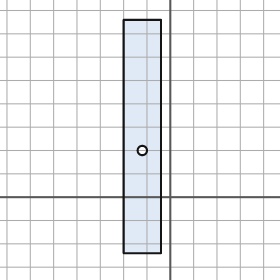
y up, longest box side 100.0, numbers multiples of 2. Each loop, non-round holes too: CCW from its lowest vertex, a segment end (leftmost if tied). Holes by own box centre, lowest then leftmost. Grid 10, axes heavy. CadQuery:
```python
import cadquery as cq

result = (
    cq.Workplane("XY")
    .moveTo(-20.0, -24.0)
    .lineTo(-4.0, -24.0)
    .lineTo(-4.0, 76.0)
    .lineTo(-20.0, 76.0)
    .close()
    .moveTo(-12.0, 20.0)
    .circle(2.0)
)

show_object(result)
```